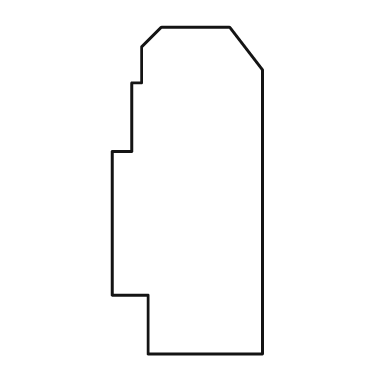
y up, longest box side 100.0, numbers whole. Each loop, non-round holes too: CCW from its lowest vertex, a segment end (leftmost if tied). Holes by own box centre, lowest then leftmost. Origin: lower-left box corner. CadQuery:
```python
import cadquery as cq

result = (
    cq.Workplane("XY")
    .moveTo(11.0, 0.0)
    .lineTo(46.0, 0.0)
    .lineTo(46.0, 87.0)
    .lineTo(36.0, 100.0)
    .lineTo(15.0, 100.0)
    .lineTo(9.0, 94.0)
    .lineTo(9.0, 83.0)
    .lineTo(6.0, 83.0)
    .lineTo(6.0, 62.0)
    .lineTo(0.0, 62.0)
    .lineTo(0.0, 18.0)
    .lineTo(11.0, 18.0)
    .close()
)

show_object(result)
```